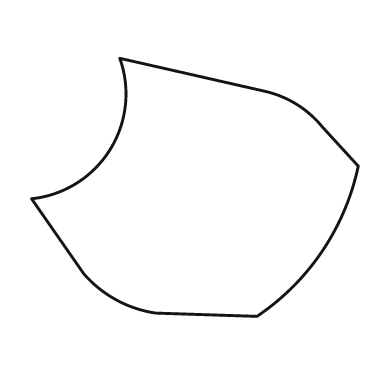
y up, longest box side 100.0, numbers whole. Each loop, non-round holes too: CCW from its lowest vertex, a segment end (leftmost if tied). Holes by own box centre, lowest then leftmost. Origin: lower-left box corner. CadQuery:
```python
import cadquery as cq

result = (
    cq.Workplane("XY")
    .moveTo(69.0, 0.0)
    .threePointArc((89.0, 20.0), (100.0, 46.0))
    .lineTo(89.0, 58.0)
    .threePointArc((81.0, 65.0), (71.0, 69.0))
    .lineTo(27.0, 79.0)
    .threePointArc((24.0, 51.0), (0.0, 36.0))
    .lineTo(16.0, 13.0)
    .threePointArc((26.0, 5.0), (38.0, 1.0))
    .close()
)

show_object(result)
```